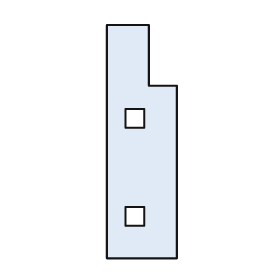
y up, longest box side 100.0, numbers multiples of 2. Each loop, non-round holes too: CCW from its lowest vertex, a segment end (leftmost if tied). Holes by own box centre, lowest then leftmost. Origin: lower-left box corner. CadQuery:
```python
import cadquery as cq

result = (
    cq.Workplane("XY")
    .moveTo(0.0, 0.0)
    .lineTo(30.0, 0.0)
    .lineTo(30.0, 74.0)
    .lineTo(18.0, 74.0)
    .lineTo(18.0, 100.0)
    .lineTo(0.0, 100.0)
    .close()
    .moveTo(8.0, 14.0)
    .lineTo(16.0, 14.0)
    .lineTo(16.0, 22.0)
    .lineTo(8.0, 22.0)
    .close()
    .moveTo(8.0, 56.0)
    .lineTo(16.0, 56.0)
    .lineTo(16.0, 64.0)
    .lineTo(8.0, 64.0)
    .close()
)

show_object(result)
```